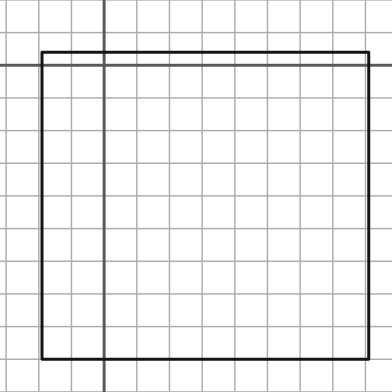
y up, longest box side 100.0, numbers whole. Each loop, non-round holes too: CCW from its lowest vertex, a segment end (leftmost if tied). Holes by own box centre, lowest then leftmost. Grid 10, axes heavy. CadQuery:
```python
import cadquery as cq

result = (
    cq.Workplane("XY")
    .moveTo(-19.0, -90.0)
    .lineTo(81.0, -90.0)
    .lineTo(81.0, 4.0)
    .lineTo(-19.0, 4.0)
    .close()
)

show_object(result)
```